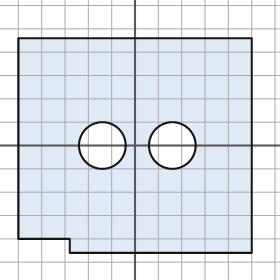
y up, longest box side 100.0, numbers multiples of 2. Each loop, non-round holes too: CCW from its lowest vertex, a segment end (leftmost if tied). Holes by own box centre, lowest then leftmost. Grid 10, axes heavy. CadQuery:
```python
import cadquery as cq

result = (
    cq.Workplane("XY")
    .moveTo(-28.0, -46.0)
    .lineTo(50.0, -46.0)
    .lineTo(50.0, 46.0)
    .lineTo(-50.0, 46.0)
    .lineTo(-50.0, -40.0)
    .lineTo(-28.0, -40.0)
    .close()
    .moveTo(-14.0, 0.0)
    .circle(10.0)
    .moveTo(16.0, 0.0)
    .circle(10.0)
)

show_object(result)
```